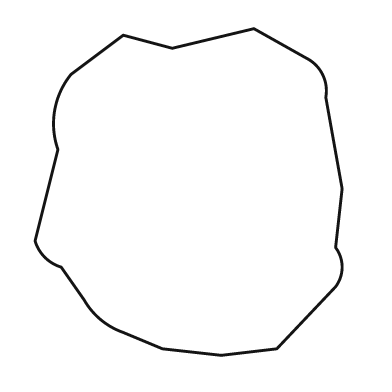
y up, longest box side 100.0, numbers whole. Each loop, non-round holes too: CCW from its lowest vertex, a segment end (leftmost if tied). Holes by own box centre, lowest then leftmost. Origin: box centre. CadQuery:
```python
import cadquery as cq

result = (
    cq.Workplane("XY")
    .moveTo(10.0, -50.0)
    .lineTo(27.0, -48.0)
    .lineTo(45.0, -29.0)
    .threePointArc((47.0, -23.0), (45.0, -17.0))
    .lineTo(47.0, 1.0)
    .lineTo(42.0, 29.0)
    .threePointArc((41.0, 36.0), (36.0, 41.0))
    .lineTo(20.0, 50.0)
    .lineTo(-5.0, 44.0)
    .lineTo(-20.0, 48.0)
    .lineTo(-36.0, 36.0)
    .threePointArc((-41.0, 25.0), (-40.0, 13.0))
    .lineTo(-47.0, -15.0)
    .threePointArc((-44.0, -20.0), (-39.0, -23.0))
    .lineTo(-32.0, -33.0)
    .threePointArc((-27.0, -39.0), (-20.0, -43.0))
    .lineTo(-8.0, -48.0)
    .close()
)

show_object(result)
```